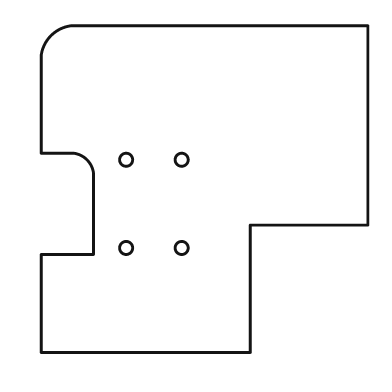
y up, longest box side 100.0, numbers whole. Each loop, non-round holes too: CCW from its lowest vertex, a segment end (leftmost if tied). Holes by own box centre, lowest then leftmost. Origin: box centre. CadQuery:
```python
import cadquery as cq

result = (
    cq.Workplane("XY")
    .moveTo(-50.0, -50.0)
    .lineTo(14.0, -50.0)
    .lineTo(14.0, -11.0)
    .lineTo(50.0, -11.0)
    .lineTo(50.0, 50.0)
    .lineTo(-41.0, 50.0)
    .threePointArc((-47.0, 47.0), (-50.0, 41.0))
    .lineTo(-50.0, 11.0)
    .lineTo(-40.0, 11.0)
    .threePointArc((-36.0, 9.0), (-34.0, 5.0))
    .lineTo(-34.0, -20.0)
    .lineTo(-50.0, -20.0)
    .close()
    .moveTo(-24.0, -18.0)
    .circle(2.0)
    .moveTo(-7.0, -18.0)
    .circle(2.0)
    .moveTo(-24.0, 9.0)
    .circle(2.0)
    .moveTo(-7.0, 9.0)
    .circle(2.0)
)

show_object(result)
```